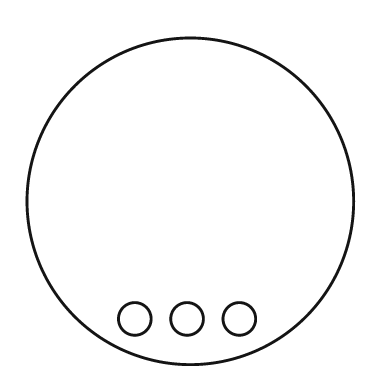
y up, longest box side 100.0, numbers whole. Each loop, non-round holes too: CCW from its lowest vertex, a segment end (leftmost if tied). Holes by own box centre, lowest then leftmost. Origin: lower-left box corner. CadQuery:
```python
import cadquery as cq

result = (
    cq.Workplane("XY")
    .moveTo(50.0, 50.0)
    .circle(50.0)
    .moveTo(33.0, 14.0)
    .circle(5.0)
    .moveTo(49.0, 14.0)
    .circle(5.0)
    .moveTo(65.0, 14.0)
    .circle(5.0)
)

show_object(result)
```